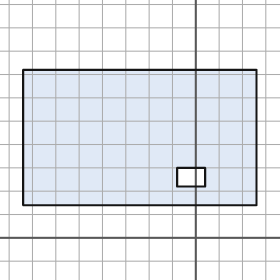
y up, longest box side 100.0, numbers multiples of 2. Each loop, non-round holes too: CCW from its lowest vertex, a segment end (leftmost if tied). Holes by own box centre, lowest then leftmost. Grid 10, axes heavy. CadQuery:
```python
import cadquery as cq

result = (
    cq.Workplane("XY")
    .moveTo(-74.0, 14.0)
    .lineTo(26.0, 14.0)
    .lineTo(26.0, 72.0)
    .lineTo(-74.0, 72.0)
    .close()
    .moveTo(-8.0, 22.0)
    .lineTo(4.0, 22.0)
    .lineTo(4.0, 30.0)
    .lineTo(-8.0, 30.0)
    .close()
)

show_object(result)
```